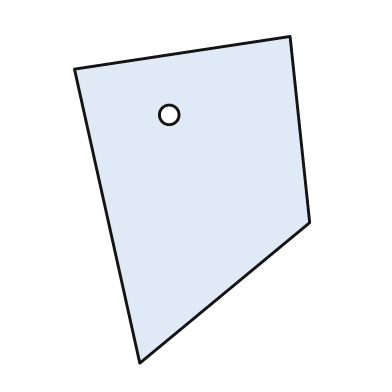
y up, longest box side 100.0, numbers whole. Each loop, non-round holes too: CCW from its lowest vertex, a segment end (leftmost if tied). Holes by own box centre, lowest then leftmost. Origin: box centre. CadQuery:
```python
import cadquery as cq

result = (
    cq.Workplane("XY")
    .moveTo(-16.0, -50.0)
    .lineTo(36.0, -7.0)
    .lineTo(30.0, 50.0)
    .lineTo(-36.0, 40.0)
    .close()
    .moveTo(-7.0, 26.0)
    .circle(3.0)
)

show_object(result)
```